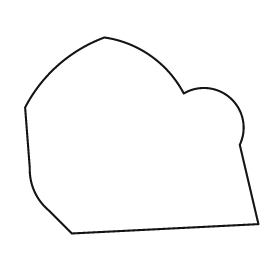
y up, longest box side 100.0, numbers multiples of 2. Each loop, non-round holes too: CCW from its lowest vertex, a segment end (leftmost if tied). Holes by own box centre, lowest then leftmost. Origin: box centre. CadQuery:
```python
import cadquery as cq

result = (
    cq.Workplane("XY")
    .moveTo(-30.0, -42.0)
    .lineTo(50.0, -38.0)
    .lineTo(42.0, -4.0)
    .threePointArc((38.0, 16.0), (18.0, 18.0))
    .threePointArc((4.0, 34.0), (-16.0, 42.0))
    .threePointArc((-36.0, 30.0), (-50.0, 12.0))
    .lineTo(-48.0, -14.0)
    .threePointArc((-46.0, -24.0), (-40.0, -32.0))
    .close()
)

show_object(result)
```